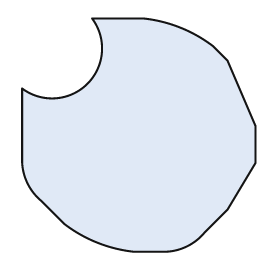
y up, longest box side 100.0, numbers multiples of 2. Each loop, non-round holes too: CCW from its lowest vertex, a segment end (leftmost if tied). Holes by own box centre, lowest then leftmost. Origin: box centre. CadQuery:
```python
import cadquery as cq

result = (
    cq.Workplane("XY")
    .moveTo(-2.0, -50.0)
    .lineTo(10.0, -50.0)
    .threePointArc((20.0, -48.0), (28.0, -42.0))
    .lineTo(38.0, -32.0)
    .lineTo(50.0, -12.0)
    .lineTo(50.0, 4.0)
    .lineTo(38.0, 32.0)
    .lineTo(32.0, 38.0)
    .threePointArc((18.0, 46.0), (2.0, 50.0))
    .lineTo(-20.0, 50.0)
    .threePointArc((-22.0, 22.0), (-50.0, 20.0))
    .lineTo(-50.0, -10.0)
    .threePointArc((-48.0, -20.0), (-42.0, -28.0))
    .lineTo(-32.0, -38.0)
    .threePointArc((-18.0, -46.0), (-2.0, -50.0))
    .close()
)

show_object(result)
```